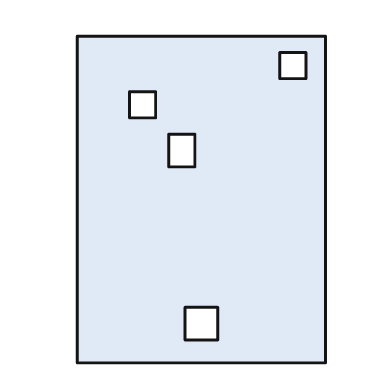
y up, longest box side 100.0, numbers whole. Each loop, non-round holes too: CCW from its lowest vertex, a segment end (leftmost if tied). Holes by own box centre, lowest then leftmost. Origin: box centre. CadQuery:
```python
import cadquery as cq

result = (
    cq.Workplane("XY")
    .moveTo(-38.0, -50.0)
    .lineTo(38.0, -50.0)
    .lineTo(38.0, 50.0)
    .lineTo(-38.0, 50.0)
    .close()
    .moveTo(-5.0, -43.0)
    .lineTo(5.0, -43.0)
    .lineTo(5.0, -33.0)
    .lineTo(-5.0, -33.0)
    .close()
    .moveTo(-10.0, 10.0)
    .lineTo(-2.0, 10.0)
    .lineTo(-2.0, 20.0)
    .lineTo(-10.0, 20.0)
    .close()
    .moveTo(-22.0, 25.0)
    .lineTo(-14.0, 25.0)
    .lineTo(-14.0, 33.0)
    .lineTo(-22.0, 33.0)
    .close()
    .moveTo(24.0, 37.0)
    .lineTo(32.0, 37.0)
    .lineTo(32.0, 45.0)
    .lineTo(24.0, 45.0)
    .close()
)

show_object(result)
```